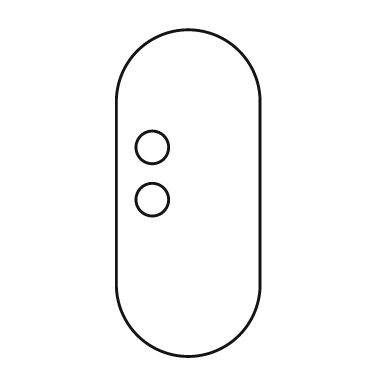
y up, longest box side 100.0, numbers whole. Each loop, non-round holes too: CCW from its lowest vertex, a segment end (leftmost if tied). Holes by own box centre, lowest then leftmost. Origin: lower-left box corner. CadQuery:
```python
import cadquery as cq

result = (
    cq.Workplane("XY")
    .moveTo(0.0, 22.0)
    .threePointArc((22.0, 0.0), (44.0, 22.0))
    .lineTo(44.0, 78.0)
    .threePointArc((22.0, 100.0), (0.0, 78.0))
    .close()
    .moveTo(11.0, 48.0)
    .circle(5.0)
    .moveTo(11.0, 64.0)
    .circle(5.0)
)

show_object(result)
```